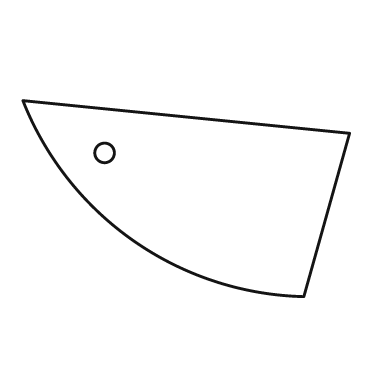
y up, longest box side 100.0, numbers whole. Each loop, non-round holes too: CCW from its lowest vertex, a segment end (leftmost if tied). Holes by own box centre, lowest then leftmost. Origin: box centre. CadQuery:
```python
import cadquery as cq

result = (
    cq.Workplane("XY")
    .moveTo(36.0, -30.0)
    .lineTo(50.0, 20.0)
    .lineTo(-50.0, 30.0)
    .threePointArc((-16.0, -13.0), (36.0, -30.0))
    .close()
    .moveTo(-25.0, 14.0)
    .circle(3.0)
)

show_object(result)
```